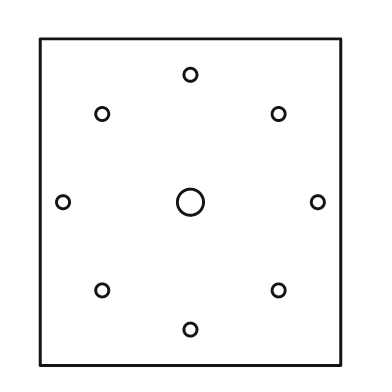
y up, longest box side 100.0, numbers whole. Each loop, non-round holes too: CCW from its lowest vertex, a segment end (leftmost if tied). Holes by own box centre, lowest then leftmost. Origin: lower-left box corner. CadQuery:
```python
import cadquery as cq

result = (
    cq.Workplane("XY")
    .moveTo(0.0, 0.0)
    .lineTo(92.0, 0.0)
    .lineTo(92.0, 100.0)
    .lineTo(0.0, 100.0)
    .close()
    .moveTo(46.0, 11.0)
    .circle(2.0)
    .moveTo(19.0, 23.0)
    .circle(2.0)
    .moveTo(73.0, 23.0)
    .circle(2.0)
    .moveTo(7.0, 50.0)
    .circle(2.0)
    .moveTo(46.0, 50.0)
    .circle(4.0)
    .moveTo(85.0, 50.0)
    .circle(2.0)
    .moveTo(19.0, 77.0)
    .circle(2.0)
    .moveTo(73.0, 77.0)
    .circle(2.0)
    .moveTo(46.0, 89.0)
    .circle(2.0)
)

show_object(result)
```